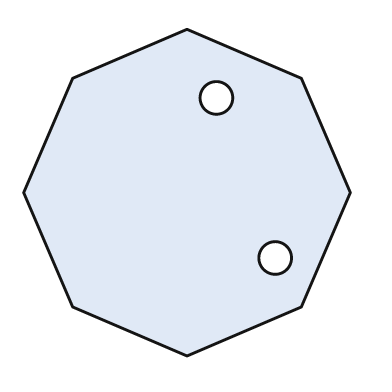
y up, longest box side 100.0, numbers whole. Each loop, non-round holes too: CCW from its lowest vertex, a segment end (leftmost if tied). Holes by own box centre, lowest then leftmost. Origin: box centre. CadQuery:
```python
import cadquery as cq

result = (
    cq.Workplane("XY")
    .moveTo(0.0, -50.0)
    .lineTo(35.0, -35.0)
    .lineTo(50.0, 0.0)
    .lineTo(35.0, 35.0)
    .lineTo(0.0, 50.0)
    .lineTo(-35.0, 35.0)
    .lineTo(-50.0, 0.0)
    .lineTo(-35.0, -35.0)
    .close()
    .moveTo(27.0, -20.0)
    .circle(5.0)
    .moveTo(9.0, 29.0)
    .circle(5.0)
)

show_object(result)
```